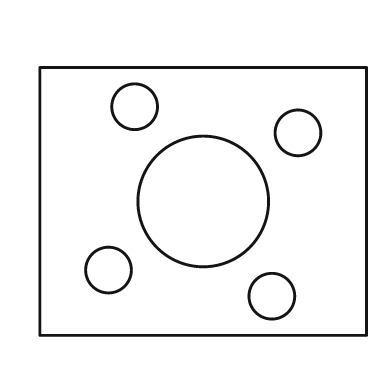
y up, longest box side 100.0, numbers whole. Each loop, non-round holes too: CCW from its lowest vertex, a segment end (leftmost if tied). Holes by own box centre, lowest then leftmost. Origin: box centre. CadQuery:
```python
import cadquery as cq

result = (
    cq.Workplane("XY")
    .moveTo(-50.0, -41.0)
    .lineTo(50.0, -41.0)
    .lineTo(50.0, 41.0)
    .lineTo(-50.0, 41.0)
    .close()
    .moveTo(21.0, -29.0)
    .circle(7.0)
    .moveTo(-29.0, -21.0)
    .circle(7.0)
    .moveTo(0.0, 0.0)
    .circle(20.0)
    .moveTo(29.0, 21.0)
    .circle(7.0)
    .moveTo(-21.0, 29.0)
    .circle(7.0)
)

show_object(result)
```